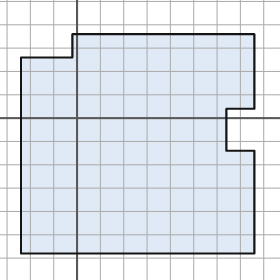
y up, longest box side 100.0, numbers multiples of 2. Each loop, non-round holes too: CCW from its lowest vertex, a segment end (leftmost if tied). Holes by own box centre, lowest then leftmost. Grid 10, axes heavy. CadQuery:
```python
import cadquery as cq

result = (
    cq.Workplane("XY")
    .moveTo(-24.0, -58.0)
    .lineTo(76.0, -58.0)
    .lineTo(76.0, -14.0)
    .lineTo(64.0, -14.0)
    .lineTo(64.0, 4.0)
    .lineTo(76.0, 4.0)
    .lineTo(76.0, 36.0)
    .lineTo(-2.0, 36.0)
    .lineTo(-2.0, 26.0)
    .lineTo(-24.0, 26.0)
    .close()
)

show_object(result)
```